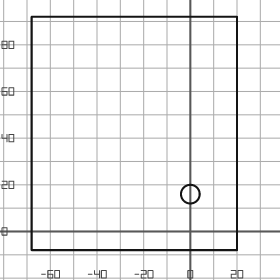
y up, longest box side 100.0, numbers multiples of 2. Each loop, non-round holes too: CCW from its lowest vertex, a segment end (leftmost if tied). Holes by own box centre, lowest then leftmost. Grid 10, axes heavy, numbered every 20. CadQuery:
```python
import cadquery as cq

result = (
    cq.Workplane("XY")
    .moveTo(-68.0, -8.0)
    .lineTo(20.0, -8.0)
    .lineTo(20.0, 92.0)
    .lineTo(-68.0, 92.0)
    .close()
    .moveTo(0.0, 16.0)
    .circle(4.0)
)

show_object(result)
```